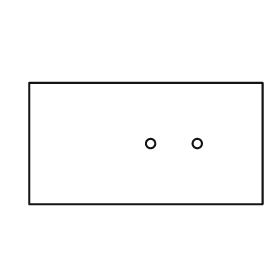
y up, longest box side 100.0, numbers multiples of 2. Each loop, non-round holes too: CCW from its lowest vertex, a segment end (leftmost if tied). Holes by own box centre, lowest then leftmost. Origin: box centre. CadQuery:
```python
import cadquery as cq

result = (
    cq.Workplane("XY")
    .moveTo(-50.0, -26.0)
    .lineTo(50.0, -26.0)
    .lineTo(50.0, 26.0)
    .lineTo(-50.0, 26.0)
    .close()
    .moveTo(2.0, 0.0)
    .circle(2.0)
    .moveTo(22.0, 0.0)
    .circle(2.0)
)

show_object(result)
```